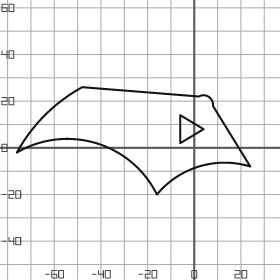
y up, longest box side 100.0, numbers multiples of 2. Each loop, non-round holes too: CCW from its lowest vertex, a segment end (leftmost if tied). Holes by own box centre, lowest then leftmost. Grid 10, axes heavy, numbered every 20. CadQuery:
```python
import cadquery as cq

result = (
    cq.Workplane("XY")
    .moveTo(-16.0, -20.0)
    .threePointArc((2.0, -8.0), (24.0, -8.0))
    .lineTo(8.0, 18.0)
    .threePointArc((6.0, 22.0), (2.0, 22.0))
    .lineTo(-48.0, 26.0)
    .threePointArc((-64.0, 14.0), (-76.0, -2.0))
    .threePointArc((-42.0, 2.0), (-16.0, -20.0))
    .close()
    .moveTo(-6.0, 2.0)
    .lineTo(4.0, 8.0)
    .lineTo(-6.0, 14.0)
    .close()
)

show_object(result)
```